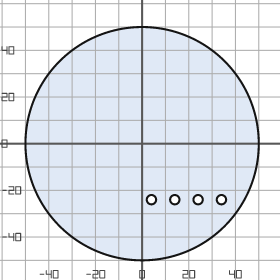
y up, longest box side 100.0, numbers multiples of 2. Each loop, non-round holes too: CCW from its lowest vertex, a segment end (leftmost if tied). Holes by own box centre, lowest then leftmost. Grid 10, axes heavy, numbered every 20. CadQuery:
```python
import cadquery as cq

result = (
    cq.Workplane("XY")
    .moveTo(0.0, 0.0)
    .circle(50.0)
    .moveTo(4.0, -24.0)
    .circle(2.0)
    .moveTo(14.0, -24.0)
    .circle(2.0)
    .moveTo(24.0, -24.0)
    .circle(2.0)
    .moveTo(34.0, -24.0)
    .circle(2.0)
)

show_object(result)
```